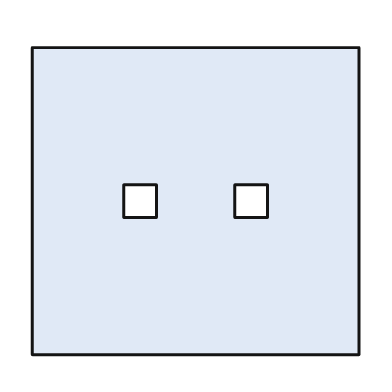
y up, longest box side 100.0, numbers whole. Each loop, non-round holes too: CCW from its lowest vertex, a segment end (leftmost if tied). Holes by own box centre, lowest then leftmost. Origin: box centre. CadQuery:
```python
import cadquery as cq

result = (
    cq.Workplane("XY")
    .moveTo(-50.0, -47.0)
    .lineTo(50.0, -47.0)
    .lineTo(50.0, 47.0)
    .lineTo(-50.0, 47.0)
    .close()
    .moveTo(-22.0, -5.0)
    .lineTo(-12.0, -5.0)
    .lineTo(-12.0, 5.0)
    .lineTo(-22.0, 5.0)
    .close()
    .moveTo(12.0, -5.0)
    .lineTo(22.0, -5.0)
    .lineTo(22.0, 5.0)
    .lineTo(12.0, 5.0)
    .close()
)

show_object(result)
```